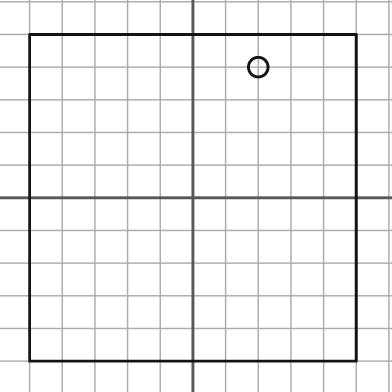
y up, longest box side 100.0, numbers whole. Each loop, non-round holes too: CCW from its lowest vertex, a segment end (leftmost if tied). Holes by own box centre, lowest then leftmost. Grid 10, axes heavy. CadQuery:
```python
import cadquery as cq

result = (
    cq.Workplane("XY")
    .moveTo(-50.0, -50.0)
    .lineTo(50.0, -50.0)
    .lineTo(50.0, 50.0)
    .lineTo(-50.0, 50.0)
    .close()
    .moveTo(20.0, 40.0)
    .circle(3.0)
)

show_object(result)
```